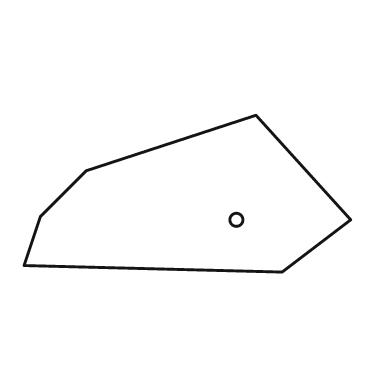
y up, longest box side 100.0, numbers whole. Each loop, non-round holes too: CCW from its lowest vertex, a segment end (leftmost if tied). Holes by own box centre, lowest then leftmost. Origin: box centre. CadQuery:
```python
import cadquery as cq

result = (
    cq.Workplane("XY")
    .moveTo(29.0, -24.0)
    .lineTo(50.0, -8.0)
    .lineTo(21.0, 24.0)
    .lineTo(-31.0, 7.0)
    .lineTo(-45.0, -7.0)
    .lineTo(-50.0, -22.0)
    .close()
    .moveTo(15.0, -8.0)
    .circle(2.0)
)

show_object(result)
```